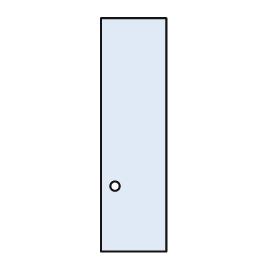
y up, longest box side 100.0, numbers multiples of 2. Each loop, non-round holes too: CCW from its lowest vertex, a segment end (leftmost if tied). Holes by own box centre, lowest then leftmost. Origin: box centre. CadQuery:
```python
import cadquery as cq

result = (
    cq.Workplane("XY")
    .moveTo(-14.0, -50.0)
    .lineTo(14.0, -50.0)
    .lineTo(14.0, 50.0)
    .lineTo(-14.0, 50.0)
    .close()
    .moveTo(-8.0, -22.0)
    .circle(2.0)
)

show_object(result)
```